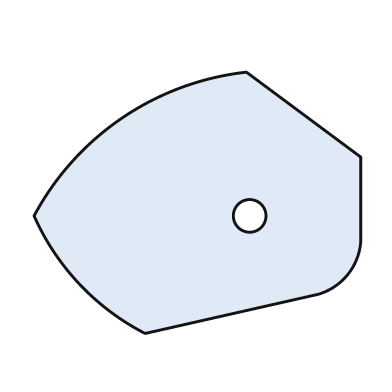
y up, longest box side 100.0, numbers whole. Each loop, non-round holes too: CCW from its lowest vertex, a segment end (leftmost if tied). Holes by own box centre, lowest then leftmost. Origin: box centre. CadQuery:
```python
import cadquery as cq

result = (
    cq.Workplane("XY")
    .moveTo(-16.0, -40.0)
    .lineTo(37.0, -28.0)
    .threePointArc((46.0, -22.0), (50.0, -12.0))
    .lineTo(50.0, 14.0)
    .lineTo(15.0, 40.0)
    .threePointArc((-23.0, 26.0), (-50.0, -4.0))
    .threePointArc((-36.0, -25.0), (-16.0, -40.0))
    .close()
    .moveTo(16.0, -4.0)
    .circle(5.0)
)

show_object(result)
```